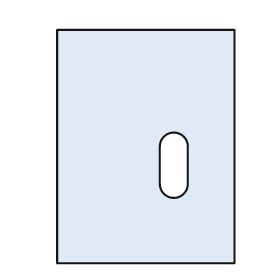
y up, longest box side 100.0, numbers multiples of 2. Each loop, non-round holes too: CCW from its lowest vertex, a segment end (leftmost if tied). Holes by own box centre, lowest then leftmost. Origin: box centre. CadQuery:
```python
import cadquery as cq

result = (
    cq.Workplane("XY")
    .moveTo(-38.0, -50.0)
    .lineTo(38.0, -50.0)
    .lineTo(38.0, 50.0)
    .lineTo(-38.0, 50.0)
    .close()
    .moveTo(6.0, -16.0)
    .threePointArc((12.0, -22.0), (18.0, -16.0))
    .lineTo(18.0, 0.0)
    .threePointArc((12.0, 6.0), (6.0, 0.0))
    .close()
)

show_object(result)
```